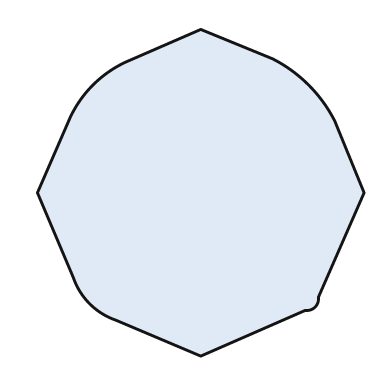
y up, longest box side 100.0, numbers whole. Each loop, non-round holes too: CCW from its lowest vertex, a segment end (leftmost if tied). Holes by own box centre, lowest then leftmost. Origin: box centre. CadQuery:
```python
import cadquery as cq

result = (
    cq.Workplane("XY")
    .moveTo(0.0, -50.0)
    .lineTo(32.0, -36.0)
    .threePointArc((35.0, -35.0), (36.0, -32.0))
    .lineTo(50.0, 0.0)
    .lineTo(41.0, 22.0)
    .threePointArc((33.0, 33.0), (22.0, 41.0))
    .lineTo(0.0, 50.0)
    .lineTo(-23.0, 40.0)
    .threePointArc((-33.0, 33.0), (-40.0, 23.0))
    .lineTo(-50.0, 0.0)
    .lineTo(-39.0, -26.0)
    .threePointArc((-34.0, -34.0), (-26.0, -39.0))
    .close()
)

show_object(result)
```